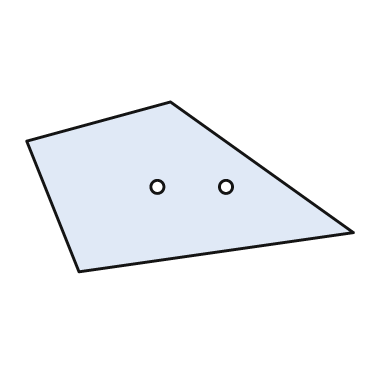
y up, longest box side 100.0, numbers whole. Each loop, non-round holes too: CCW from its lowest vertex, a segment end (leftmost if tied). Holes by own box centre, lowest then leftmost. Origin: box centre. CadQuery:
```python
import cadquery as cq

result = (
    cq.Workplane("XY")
    .moveTo(-34.0, -26.0)
    .lineTo(50.0, -14.0)
    .lineTo(-6.0, 26.0)
    .lineTo(-50.0, 14.0)
    .close()
    .moveTo(-10.0, 0.0)
    .circle(2.0)
    .moveTo(11.0, 0.0)
    .circle(2.0)
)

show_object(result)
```